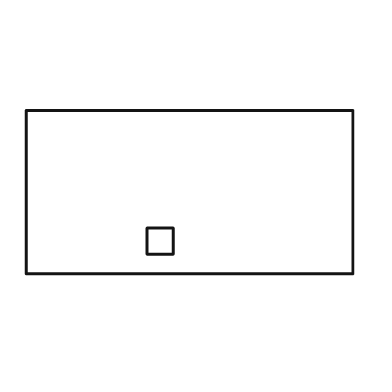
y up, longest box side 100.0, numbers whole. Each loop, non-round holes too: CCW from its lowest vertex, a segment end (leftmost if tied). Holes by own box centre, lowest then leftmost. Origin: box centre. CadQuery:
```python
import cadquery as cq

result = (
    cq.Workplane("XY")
    .moveTo(-50.0, -25.0)
    .lineTo(50.0, -25.0)
    .lineTo(50.0, 25.0)
    .lineTo(-50.0, 25.0)
    .close()
    .moveTo(-13.0, -19.0)
    .lineTo(-5.0, -19.0)
    .lineTo(-5.0, -11.0)
    .lineTo(-13.0, -11.0)
    .close()
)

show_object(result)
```